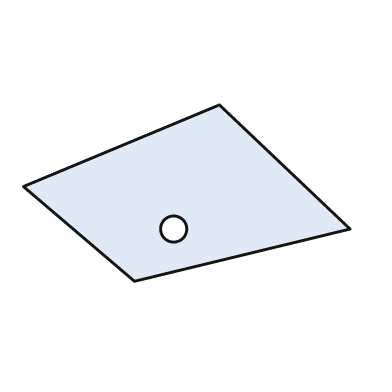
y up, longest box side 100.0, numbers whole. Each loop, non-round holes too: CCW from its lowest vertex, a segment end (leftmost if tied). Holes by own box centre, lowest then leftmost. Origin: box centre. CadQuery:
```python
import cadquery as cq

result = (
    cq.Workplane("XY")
    .moveTo(-16.0, -27.0)
    .lineTo(50.0, -11.0)
    .lineTo(10.0, 27.0)
    .lineTo(-50.0, 2.0)
    .close()
    .moveTo(-4.0, -11.0)
    .circle(4.0)
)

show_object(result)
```